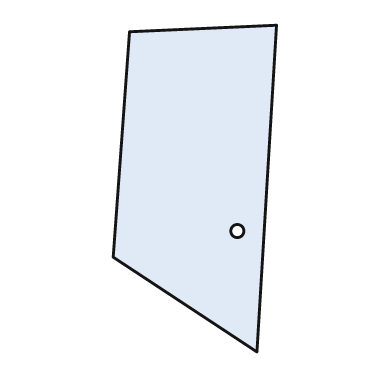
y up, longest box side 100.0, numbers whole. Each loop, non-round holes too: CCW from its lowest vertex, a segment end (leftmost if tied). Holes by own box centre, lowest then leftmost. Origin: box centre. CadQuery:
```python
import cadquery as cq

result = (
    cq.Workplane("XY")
    .moveTo(19.0, -50.0)
    .lineTo(25.0, 50.0)
    .lineTo(-20.0, 48.0)
    .lineTo(-25.0, -21.0)
    .close()
    .moveTo(13.0, -13.0)
    .circle(2.0)
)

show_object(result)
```